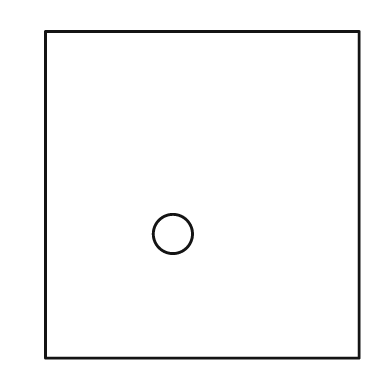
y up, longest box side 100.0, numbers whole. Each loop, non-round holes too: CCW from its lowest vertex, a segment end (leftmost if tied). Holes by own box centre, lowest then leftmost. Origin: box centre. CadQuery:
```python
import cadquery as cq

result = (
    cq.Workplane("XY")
    .moveTo(-48.0, -50.0)
    .lineTo(48.0, -50.0)
    .lineTo(48.0, 50.0)
    .lineTo(-48.0, 50.0)
    .close()
    .moveTo(-9.0, -12.0)
    .circle(6.0)
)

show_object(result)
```